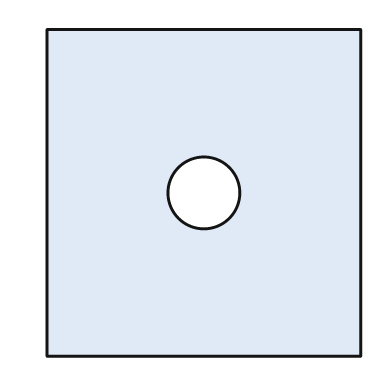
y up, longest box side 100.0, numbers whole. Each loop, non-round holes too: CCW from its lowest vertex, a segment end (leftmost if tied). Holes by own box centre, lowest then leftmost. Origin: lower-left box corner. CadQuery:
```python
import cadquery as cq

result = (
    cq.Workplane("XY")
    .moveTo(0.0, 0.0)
    .lineTo(96.0, 0.0)
    .lineTo(96.0, 100.0)
    .lineTo(0.0, 100.0)
    .close()
    .moveTo(48.0, 50.0)
    .circle(11.0)
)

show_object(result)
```